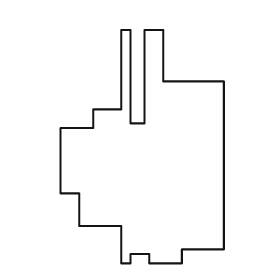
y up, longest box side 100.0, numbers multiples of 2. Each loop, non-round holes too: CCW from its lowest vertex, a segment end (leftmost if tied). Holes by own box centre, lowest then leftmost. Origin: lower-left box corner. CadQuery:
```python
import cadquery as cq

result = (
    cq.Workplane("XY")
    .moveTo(26.0, 0.0)
    .lineTo(30.0, 0.0)
    .lineTo(30.0, 4.0)
    .lineTo(38.0, 4.0)
    .lineTo(38.0, 0.0)
    .lineTo(52.0, 0.0)
    .lineTo(52.0, 6.0)
    .lineTo(70.0, 6.0)
    .lineTo(70.0, 78.0)
    .lineTo(44.0, 78.0)
    .lineTo(44.0, 100.0)
    .lineTo(36.0, 100.0)
    .lineTo(36.0, 60.0)
    .lineTo(30.0, 60.0)
    .lineTo(30.0, 100.0)
    .lineTo(26.0, 100.0)
    .lineTo(26.0, 66.0)
    .lineTo(14.0, 66.0)
    .lineTo(14.0, 58.0)
    .lineTo(0.0, 58.0)
    .lineTo(0.0, 30.0)
    .lineTo(8.0, 30.0)
    .lineTo(8.0, 16.0)
    .lineTo(26.0, 16.0)
    .close()
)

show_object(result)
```